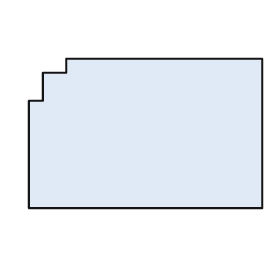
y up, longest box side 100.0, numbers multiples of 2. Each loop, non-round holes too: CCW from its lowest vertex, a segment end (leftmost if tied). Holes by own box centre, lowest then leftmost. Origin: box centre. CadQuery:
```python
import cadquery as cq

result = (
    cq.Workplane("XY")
    .moveTo(-50.0, -32.0)
    .lineTo(50.0, -32.0)
    .lineTo(50.0, 32.0)
    .lineTo(-34.0, 32.0)
    .lineTo(-34.0, 26.0)
    .lineTo(-44.0, 26.0)
    .lineTo(-44.0, 14.0)
    .lineTo(-50.0, 14.0)
    .close()
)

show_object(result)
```